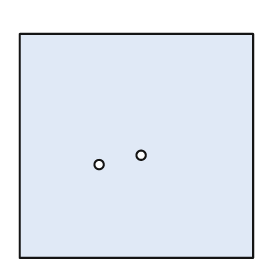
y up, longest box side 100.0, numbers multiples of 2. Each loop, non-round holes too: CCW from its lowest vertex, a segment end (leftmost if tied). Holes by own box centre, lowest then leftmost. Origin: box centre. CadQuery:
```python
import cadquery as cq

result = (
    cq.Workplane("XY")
    .moveTo(-50.0, -48.0)
    .lineTo(50.0, -48.0)
    .lineTo(50.0, 48.0)
    .lineTo(-50.0, 48.0)
    .close()
    .moveTo(-16.0, -8.0)
    .circle(2.0)
    .moveTo(2.0, -4.0)
    .circle(2.0)
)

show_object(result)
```